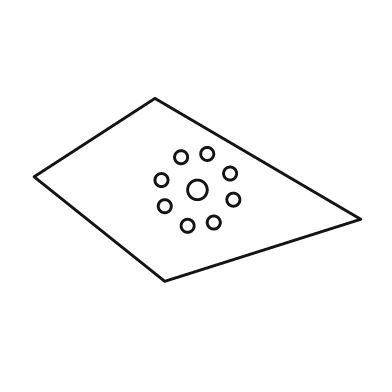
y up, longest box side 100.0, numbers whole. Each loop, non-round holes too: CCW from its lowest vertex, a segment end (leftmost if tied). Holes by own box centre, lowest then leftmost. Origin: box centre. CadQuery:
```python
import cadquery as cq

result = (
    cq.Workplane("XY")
    .moveTo(-10.0, -28.0)
    .lineTo(50.0, -9.0)
    .lineTo(-13.0, 28.0)
    .lineTo(-50.0, 4.0)
    .close()
    .moveTo(-3.0, -11.0)
    .circle(2.0)
    .moveTo(5.0, -10.0)
    .circle(2.0)
    .moveTo(-10.0, -5.0)
    .circle(2.0)
    .moveTo(11.0, -3.0)
    .circle(2.0)
    .moveTo(0.0, 0.0)
    .circle(3.0)
    .moveTo(-11.0, 3.0)
    .circle(2.0)
    .moveTo(10.0, 5.0)
    .circle(2.0)
    .moveTo(-5.0, 10.0)
    .circle(2.0)
    .moveTo(3.0, 11.0)
    .circle(2.0)
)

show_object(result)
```